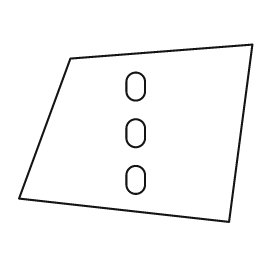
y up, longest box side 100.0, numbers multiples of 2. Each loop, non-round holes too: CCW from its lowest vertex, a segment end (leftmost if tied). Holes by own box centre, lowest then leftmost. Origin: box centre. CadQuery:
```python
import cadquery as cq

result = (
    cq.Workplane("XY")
    .moveTo(40.0, -38.0)
    .lineTo(50.0, 38.0)
    .lineTo(-28.0, 32.0)
    .lineTo(-50.0, -28.0)
    .close()
    .moveTo(-4.0, -22.0)
    .threePointArc((0.0, -26.0), (4.0, -22.0))
    .lineTo(4.0, -18.0)
    .threePointArc((0.0, -14.0), (-4.0, -18.0))
    .close()
    .moveTo(-4.0, -2.0)
    .threePointArc((0.0, -6.0), (4.0, -2.0))
    .lineTo(4.0, 2.0)
    .threePointArc((0.0, 6.0), (-4.0, 2.0))
    .close()
    .moveTo(-4.0, 18.0)
    .threePointArc((0.0, 14.0), (4.0, 18.0))
    .lineTo(4.0, 22.0)
    .threePointArc((0.0, 26.0), (-4.0, 22.0))
    .close()
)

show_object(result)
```